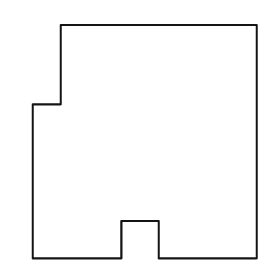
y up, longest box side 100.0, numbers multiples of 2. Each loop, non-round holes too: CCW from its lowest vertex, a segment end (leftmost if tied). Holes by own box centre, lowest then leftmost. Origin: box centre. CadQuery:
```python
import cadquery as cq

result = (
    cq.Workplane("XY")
    .moveTo(-48.0, -50.0)
    .lineTo(-10.0, -50.0)
    .lineTo(-10.0, -34.0)
    .lineTo(6.0, -34.0)
    .lineTo(6.0, -50.0)
    .lineTo(48.0, -50.0)
    .lineTo(48.0, 50.0)
    .lineTo(-36.0, 50.0)
    .lineTo(-36.0, 16.0)
    .lineTo(-48.0, 16.0)
    .close()
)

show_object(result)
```